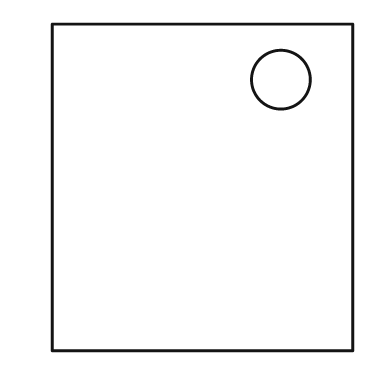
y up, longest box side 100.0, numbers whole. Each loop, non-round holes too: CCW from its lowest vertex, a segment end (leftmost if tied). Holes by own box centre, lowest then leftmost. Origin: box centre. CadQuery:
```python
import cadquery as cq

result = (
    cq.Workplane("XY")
    .moveTo(-46.0, -50.0)
    .lineTo(46.0, -50.0)
    .lineTo(46.0, 50.0)
    .lineTo(-46.0, 50.0)
    .close()
    .moveTo(24.0, 33.0)
    .circle(9.0)
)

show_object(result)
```